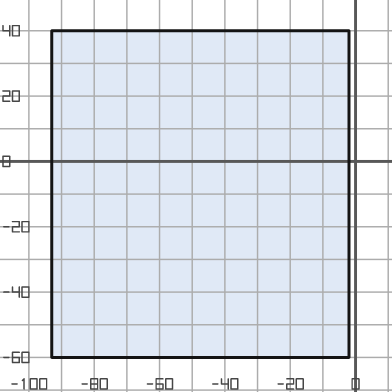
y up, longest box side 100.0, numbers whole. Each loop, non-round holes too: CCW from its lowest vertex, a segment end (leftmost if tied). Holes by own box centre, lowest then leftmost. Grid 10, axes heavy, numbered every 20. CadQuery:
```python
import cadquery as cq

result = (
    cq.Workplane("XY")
    .moveTo(-93.0, -60.0)
    .lineTo(-2.0, -60.0)
    .lineTo(-2.0, 40.0)
    .lineTo(-93.0, 40.0)
    .close()
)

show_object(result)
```